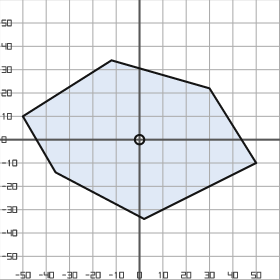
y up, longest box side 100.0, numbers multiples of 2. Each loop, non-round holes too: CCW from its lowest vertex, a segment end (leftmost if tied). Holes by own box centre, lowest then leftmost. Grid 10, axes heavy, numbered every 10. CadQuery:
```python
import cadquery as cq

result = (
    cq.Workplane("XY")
    .moveTo(2.0, -34.0)
    .lineTo(50.0, -10.0)
    .lineTo(30.0, 22.0)
    .lineTo(-12.0, 34.0)
    .lineTo(-50.0, 10.0)
    .lineTo(-36.0, -14.0)
    .close()
    .moveTo(0.0, 0.0)
    .circle(2.0)
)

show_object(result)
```